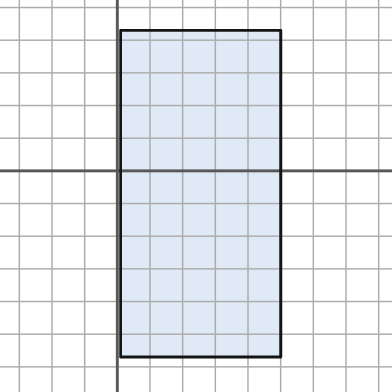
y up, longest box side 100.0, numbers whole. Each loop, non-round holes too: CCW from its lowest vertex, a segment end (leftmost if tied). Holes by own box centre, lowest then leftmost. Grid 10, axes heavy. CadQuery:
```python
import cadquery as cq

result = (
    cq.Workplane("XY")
    .moveTo(1.0, -57.0)
    .lineTo(50.0, -57.0)
    .lineTo(50.0, 43.0)
    .lineTo(1.0, 43.0)
    .close()
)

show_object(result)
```